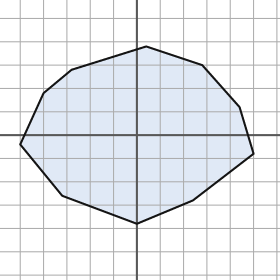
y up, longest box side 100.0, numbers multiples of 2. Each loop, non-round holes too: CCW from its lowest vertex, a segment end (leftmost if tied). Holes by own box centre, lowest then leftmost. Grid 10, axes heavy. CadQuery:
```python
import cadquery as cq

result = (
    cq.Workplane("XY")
    .moveTo(0.0, -38.0)
    .lineTo(24.0, -28.0)
    .lineTo(50.0, -8.0)
    .lineTo(44.0, 12.0)
    .lineTo(28.0, 30.0)
    .lineTo(4.0, 38.0)
    .lineTo(-28.0, 28.0)
    .lineTo(-40.0, 18.0)
    .lineTo(-50.0, -4.0)
    .lineTo(-32.0, -26.0)
    .close()
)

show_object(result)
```